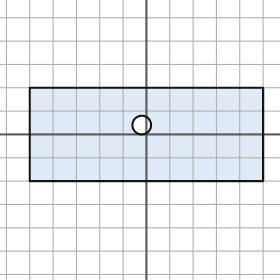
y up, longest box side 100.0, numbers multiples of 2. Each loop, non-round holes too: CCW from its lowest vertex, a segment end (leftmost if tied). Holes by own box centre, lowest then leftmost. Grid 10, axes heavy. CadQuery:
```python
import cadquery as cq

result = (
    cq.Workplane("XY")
    .moveTo(-50.0, -20.0)
    .lineTo(50.0, -20.0)
    .lineTo(50.0, 20.0)
    .lineTo(-50.0, 20.0)
    .close()
    .moveTo(-2.0, 4.0)
    .circle(4.0)
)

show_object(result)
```